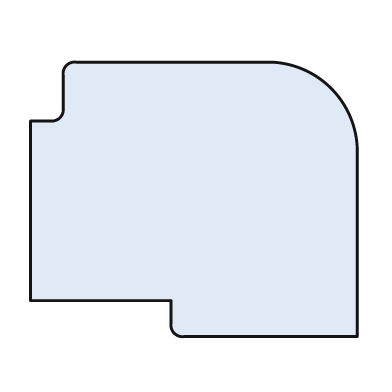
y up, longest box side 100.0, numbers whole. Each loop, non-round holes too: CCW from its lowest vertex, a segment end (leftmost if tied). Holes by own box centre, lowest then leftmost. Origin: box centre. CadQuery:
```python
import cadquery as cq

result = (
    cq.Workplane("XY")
    .moveTo(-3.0, -42.0)
    .lineTo(50.0, -42.0)
    .lineTo(50.0, 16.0)
    .threePointArc((42.0, 34.0), (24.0, 42.0))
    .lineTo(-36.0, 42.0)
    .threePointArc((-39.0, 41.0), (-40.0, 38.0))
    .lineTo(-40.0, 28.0)
    .threePointArc((-41.0, 25.0), (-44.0, 24.0))
    .lineTo(-50.0, 24.0)
    .lineTo(-50.0, -31.0)
    .lineTo(-7.0, -31.0)
    .lineTo(-7.0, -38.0)
    .threePointArc((-6.0, -41.0), (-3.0, -42.0))
    .close()
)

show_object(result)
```